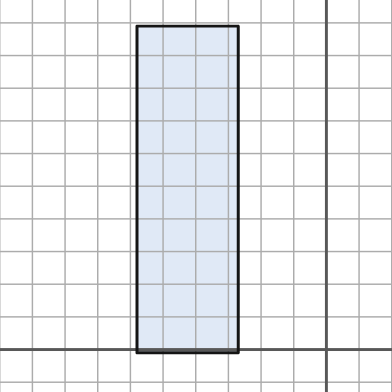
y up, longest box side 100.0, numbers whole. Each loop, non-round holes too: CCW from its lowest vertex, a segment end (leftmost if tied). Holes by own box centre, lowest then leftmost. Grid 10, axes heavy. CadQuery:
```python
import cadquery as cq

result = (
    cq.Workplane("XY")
    .moveTo(-58.0, -1.0)
    .lineTo(-27.0, -1.0)
    .lineTo(-27.0, 99.0)
    .lineTo(-58.0, 99.0)
    .close()
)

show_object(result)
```